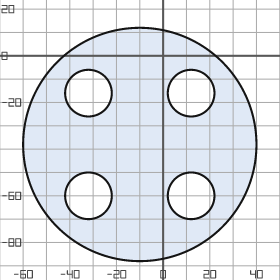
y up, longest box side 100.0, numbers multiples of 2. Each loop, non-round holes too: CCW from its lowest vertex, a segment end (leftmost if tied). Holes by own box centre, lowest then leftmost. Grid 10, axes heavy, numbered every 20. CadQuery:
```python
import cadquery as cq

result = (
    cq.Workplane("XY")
    .moveTo(-10.0, -38.0)
    .circle(50.0)
    .moveTo(-32.0, -60.0)
    .circle(10.0)
    .moveTo(12.0, -60.0)
    .circle(10.0)
    .moveTo(-32.0, -16.0)
    .circle(10.0)
    .moveTo(12.0, -16.0)
    .circle(10.0)
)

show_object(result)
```